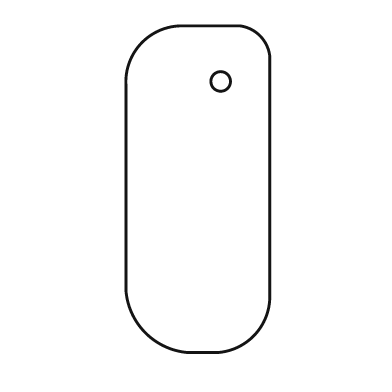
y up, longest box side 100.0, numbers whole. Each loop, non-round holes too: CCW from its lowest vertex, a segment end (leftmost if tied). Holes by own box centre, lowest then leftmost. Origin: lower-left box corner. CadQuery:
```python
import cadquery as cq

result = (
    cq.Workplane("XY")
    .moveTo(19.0, 0.0)
    .lineTo(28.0, 0.0)
    .threePointArc((39.0, 5.0), (44.0, 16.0))
    .lineTo(44.0, 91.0)
    .threePointArc((41.0, 97.0), (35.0, 100.0))
    .lineTo(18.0, 100.0)
    .threePointArc((5.0, 95.0), (0.0, 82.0))
    .lineTo(0.0, 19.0)
    .threePointArc((6.0, 6.0), (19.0, 0.0))
    .close()
    .moveTo(29.0, 83.0)
    .circle(3.0)
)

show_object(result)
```